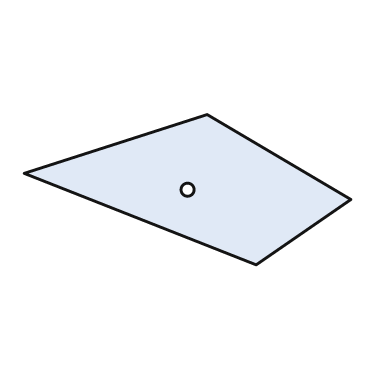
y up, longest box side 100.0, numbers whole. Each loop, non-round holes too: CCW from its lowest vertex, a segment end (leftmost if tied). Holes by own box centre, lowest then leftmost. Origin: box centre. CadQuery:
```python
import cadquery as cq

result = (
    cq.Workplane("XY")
    .moveTo(21.0, -23.0)
    .lineTo(50.0, -3.0)
    .lineTo(6.0, 23.0)
    .lineTo(-50.0, 5.0)
    .close()
    .moveTo(0.0, 0.0)
    .circle(2.0)
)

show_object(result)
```